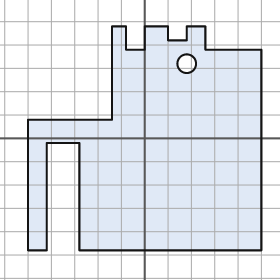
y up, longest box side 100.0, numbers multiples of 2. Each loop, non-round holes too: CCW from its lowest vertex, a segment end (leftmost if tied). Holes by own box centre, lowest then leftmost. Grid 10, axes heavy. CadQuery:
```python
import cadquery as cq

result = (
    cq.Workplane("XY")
    .moveTo(-50.0, -48.0)
    .lineTo(-42.0, -48.0)
    .lineTo(-42.0, -2.0)
    .lineTo(-28.0, -2.0)
    .lineTo(-28.0, -48.0)
    .lineTo(50.0, -48.0)
    .lineTo(50.0, 38.0)
    .lineTo(26.0, 38.0)
    .lineTo(26.0, 48.0)
    .lineTo(18.0, 48.0)
    .lineTo(18.0, 42.0)
    .lineTo(10.0, 42.0)
    .lineTo(10.0, 48.0)
    .lineTo(0.0, 48.0)
    .lineTo(0.0, 38.0)
    .lineTo(-8.0, 38.0)
    .lineTo(-8.0, 48.0)
    .lineTo(-14.0, 48.0)
    .lineTo(-14.0, 8.0)
    .lineTo(-50.0, 8.0)
    .close()
    .moveTo(18.0, 32.0)
    .circle(4.0)
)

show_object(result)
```